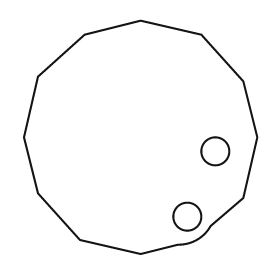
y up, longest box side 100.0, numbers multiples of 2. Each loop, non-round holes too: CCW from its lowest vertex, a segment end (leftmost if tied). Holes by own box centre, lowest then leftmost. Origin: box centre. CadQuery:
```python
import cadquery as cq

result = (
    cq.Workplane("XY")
    .moveTo(0.0, -50.0)
    .lineTo(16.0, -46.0)
    .threePointArc((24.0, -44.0), (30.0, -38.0))
    .lineTo(44.0, -26.0)
    .lineTo(50.0, 0.0)
    .lineTo(44.0, 24.0)
    .lineTo(26.0, 44.0)
    .lineTo(0.0, 50.0)
    .lineTo(-24.0, 44.0)
    .lineTo(-44.0, 26.0)
    .lineTo(-50.0, 0.0)
    .lineTo(-44.0, -24.0)
    .lineTo(-26.0, -44.0)
    .close()
    .moveTo(20.0, -34.0)
    .circle(6.0)
    .moveTo(32.0, -6.0)
    .circle(6.0)
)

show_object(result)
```